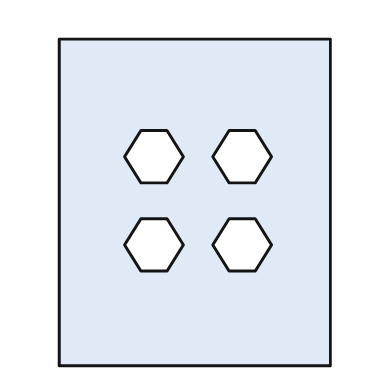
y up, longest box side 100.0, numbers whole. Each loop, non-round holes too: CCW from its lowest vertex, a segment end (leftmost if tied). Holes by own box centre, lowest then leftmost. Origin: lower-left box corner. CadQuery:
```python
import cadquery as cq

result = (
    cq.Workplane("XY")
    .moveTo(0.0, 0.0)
    .lineTo(83.0, 0.0)
    .lineTo(83.0, 100.0)
    .lineTo(0.0, 100.0)
    .close()
    .moveTo(25.0, 29.0)
    .lineTo(33.0, 29.0)
    .lineTo(38.0, 37.0)
    .lineTo(33.0, 45.0)
    .lineTo(25.0, 45.0)
    .lineTo(20.0, 37.0)
    .close()
    .moveTo(52.0, 29.0)
    .lineTo(60.0, 29.0)
    .lineTo(65.0, 37.0)
    .lineTo(60.0, 45.0)
    .lineTo(52.0, 45.0)
    .lineTo(47.0, 37.0)
    .close()
    .moveTo(25.0, 56.0)
    .lineTo(33.0, 56.0)
    .lineTo(38.0, 64.0)
    .lineTo(33.0, 72.0)
    .lineTo(25.0, 72.0)
    .lineTo(20.0, 64.0)
    .close()
    .moveTo(52.0, 56.0)
    .lineTo(60.0, 56.0)
    .lineTo(65.0, 64.0)
    .lineTo(60.0, 72.0)
    .lineTo(52.0, 72.0)
    .lineTo(47.0, 64.0)
    .close()
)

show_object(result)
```